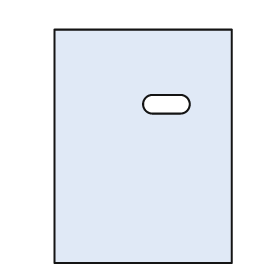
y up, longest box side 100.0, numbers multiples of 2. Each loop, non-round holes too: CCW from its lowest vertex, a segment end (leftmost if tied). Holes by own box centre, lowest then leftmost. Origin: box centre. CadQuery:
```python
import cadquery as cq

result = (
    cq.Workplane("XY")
    .moveTo(-38.0, -50.0)
    .lineTo(38.0, -50.0)
    .lineTo(38.0, 50.0)
    .lineTo(-38.0, 50.0)
    .close()
    .moveTo(4.0, 14.0)
    .lineTo(16.0, 14.0)
    .threePointArc((20.0, 18.0), (16.0, 22.0))
    .lineTo(4.0, 22.0)
    .threePointArc((0.0, 18.0), (4.0, 14.0))
    .close()
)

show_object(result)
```